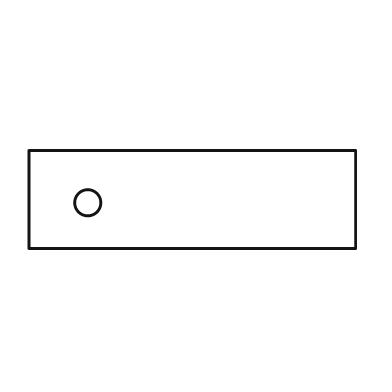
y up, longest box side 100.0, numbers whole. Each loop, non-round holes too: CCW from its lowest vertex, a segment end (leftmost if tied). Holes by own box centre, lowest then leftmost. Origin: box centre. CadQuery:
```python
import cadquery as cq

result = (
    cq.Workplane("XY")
    .moveTo(-50.0, -15.0)
    .lineTo(50.0, -15.0)
    .lineTo(50.0, 15.0)
    .lineTo(-50.0, 15.0)
    .close()
    .moveTo(-32.0, -1.0)
    .circle(4.0)
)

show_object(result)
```